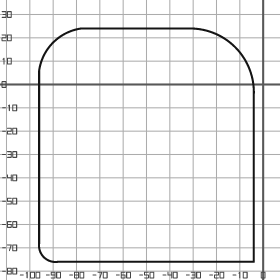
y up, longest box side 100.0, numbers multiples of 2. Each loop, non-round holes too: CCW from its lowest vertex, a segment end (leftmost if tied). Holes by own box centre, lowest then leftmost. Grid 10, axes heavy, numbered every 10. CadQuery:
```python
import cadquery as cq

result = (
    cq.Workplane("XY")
    .moveTo(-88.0, -76.0)
    .lineTo(-4.0, -76.0)
    .lineTo(-4.0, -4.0)
    .threePointArc((-12.0, 16.0), (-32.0, 24.0))
    .lineTo(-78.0, 24.0)
    .threePointArc((-90.0, 18.0), (-96.0, 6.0))
    .lineTo(-96.0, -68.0)
    .threePointArc((-94.0, -74.0), (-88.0, -76.0))
    .close()
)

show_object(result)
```